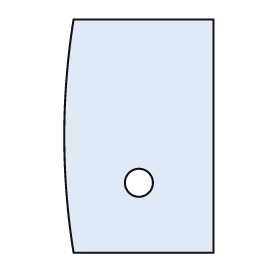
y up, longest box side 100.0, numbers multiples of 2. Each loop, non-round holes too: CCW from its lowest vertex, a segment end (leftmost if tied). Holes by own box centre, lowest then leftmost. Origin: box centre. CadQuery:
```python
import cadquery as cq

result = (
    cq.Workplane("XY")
    .moveTo(-28.0, -50.0)
    .lineTo(32.0, -50.0)
    .lineTo(32.0, 50.0)
    .lineTo(-28.0, 50.0)
    .threePointArc((-32.0, 0.0), (-28.0, -50.0))
    .close()
    .moveTo(0.0, -20.0)
    .circle(6.0)
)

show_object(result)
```